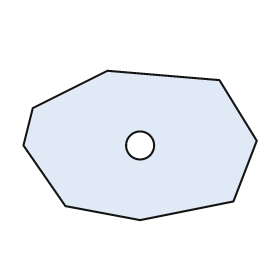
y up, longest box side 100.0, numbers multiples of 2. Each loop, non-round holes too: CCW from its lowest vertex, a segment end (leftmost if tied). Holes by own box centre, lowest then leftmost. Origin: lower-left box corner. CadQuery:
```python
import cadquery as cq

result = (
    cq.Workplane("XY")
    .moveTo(50.0, 0.0)
    .lineTo(90.0, 8.0)
    .lineTo(100.0, 34.0)
    .lineTo(84.0, 60.0)
    .lineTo(36.0, 64.0)
    .lineTo(4.0, 48.0)
    .lineTo(0.0, 32.0)
    .lineTo(18.0, 6.0)
    .close()
    .moveTo(50.0, 32.0)
    .circle(6.0)
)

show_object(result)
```